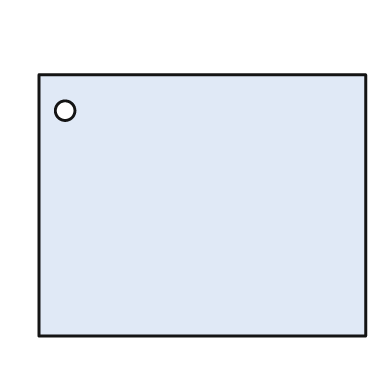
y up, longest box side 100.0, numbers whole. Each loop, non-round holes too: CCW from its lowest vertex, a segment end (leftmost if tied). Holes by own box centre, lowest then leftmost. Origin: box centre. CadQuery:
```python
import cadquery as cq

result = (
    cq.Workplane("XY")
    .moveTo(-50.0, -40.0)
    .lineTo(50.0, -40.0)
    .lineTo(50.0, 40.0)
    .lineTo(-50.0, 40.0)
    .close()
    .moveTo(-42.0, 29.0)
    .circle(3.0)
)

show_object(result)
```